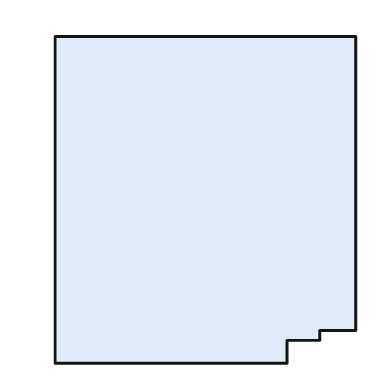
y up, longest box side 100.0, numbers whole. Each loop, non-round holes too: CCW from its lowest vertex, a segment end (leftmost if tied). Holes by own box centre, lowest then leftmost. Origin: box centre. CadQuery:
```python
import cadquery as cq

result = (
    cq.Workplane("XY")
    .moveTo(-46.0, -50.0)
    .lineTo(25.0, -50.0)
    .lineTo(25.0, -43.0)
    .lineTo(35.0, -43.0)
    .lineTo(35.0, -40.0)
    .lineTo(46.0, -40.0)
    .lineTo(46.0, 50.0)
    .lineTo(-46.0, 50.0)
    .close()
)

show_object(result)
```